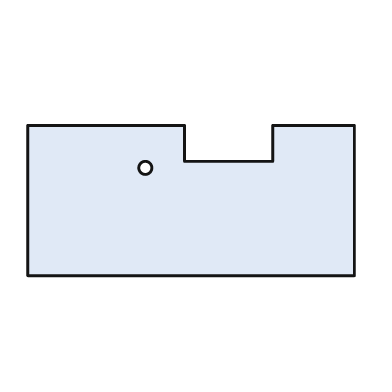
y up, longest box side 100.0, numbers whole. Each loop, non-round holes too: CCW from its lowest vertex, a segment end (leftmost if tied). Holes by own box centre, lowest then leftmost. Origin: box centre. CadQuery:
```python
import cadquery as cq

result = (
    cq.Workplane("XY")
    .moveTo(-50.0, -23.0)
    .lineTo(50.0, -23.0)
    .lineTo(50.0, 23.0)
    .lineTo(25.0, 23.0)
    .lineTo(25.0, 12.0)
    .lineTo(-2.0, 12.0)
    .lineTo(-2.0, 23.0)
    .lineTo(-50.0, 23.0)
    .close()
    .moveTo(-14.0, 10.0)
    .circle(2.0)
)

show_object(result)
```